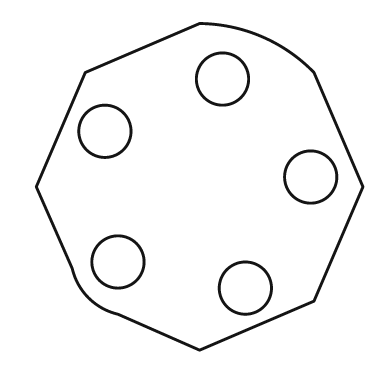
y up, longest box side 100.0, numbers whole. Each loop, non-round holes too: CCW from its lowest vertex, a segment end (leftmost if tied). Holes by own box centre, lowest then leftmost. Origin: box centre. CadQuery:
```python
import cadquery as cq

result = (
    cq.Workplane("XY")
    .moveTo(0.0, -50.0)
    .lineTo(35.0, -35.0)
    .lineTo(50.0, 0.0)
    .lineTo(35.0, 35.0)
    .threePointArc((19.0, 46.0), (0.0, 50.0))
    .lineTo(-35.0, 35.0)
    .lineTo(-50.0, 0.0)
    .lineTo(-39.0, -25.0)
    .threePointArc((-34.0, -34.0), (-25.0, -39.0))
    .close()
    .moveTo(14.0, -31.0)
    .circle(8.0)
    .moveTo(-25.0, -23.0)
    .circle(8.0)
    .moveTo(34.0, 3.0)
    .circle(8.0)
    .moveTo(-29.0, 17.0)
    .circle(8.0)
    .moveTo(7.0, 33.0)
    .circle(8.0)
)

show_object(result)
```